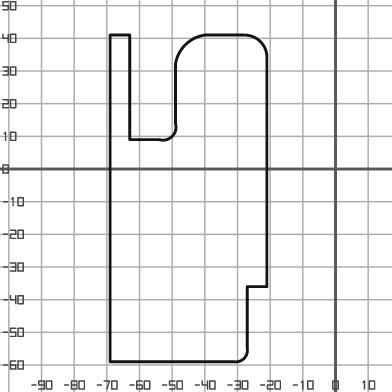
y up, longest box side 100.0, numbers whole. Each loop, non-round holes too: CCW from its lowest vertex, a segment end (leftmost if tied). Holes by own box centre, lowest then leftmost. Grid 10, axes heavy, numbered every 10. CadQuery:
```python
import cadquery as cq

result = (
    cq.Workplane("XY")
    .moveTo(-69.0, -59.0)
    .lineTo(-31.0, -59.0)
    .threePointArc((-28.0, -58.0), (-27.0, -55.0))
    .lineTo(-27.0, -36.0)
    .lineTo(-21.0, -36.0)
    .lineTo(-21.0, 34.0)
    .threePointArc((-23.0, 39.0), (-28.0, 41.0))
    .lineTo(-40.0, 41.0)
    .threePointArc((-46.0, 38.0), (-49.0, 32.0))
    .lineTo(-49.0, 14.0)
    .threePointArc((-50.0, 10.0), (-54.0, 9.0))
    .lineTo(-63.0, 9.0)
    .lineTo(-63.0, 41.0)
    .lineTo(-69.0, 41.0)
    .close()
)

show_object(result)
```